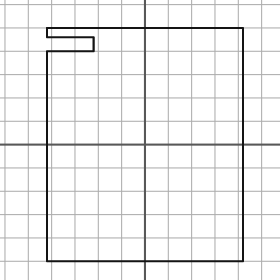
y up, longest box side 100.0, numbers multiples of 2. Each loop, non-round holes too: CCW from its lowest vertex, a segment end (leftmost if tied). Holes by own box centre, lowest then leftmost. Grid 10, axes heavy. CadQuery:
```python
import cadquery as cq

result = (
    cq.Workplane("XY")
    .moveTo(-42.0, -50.0)
    .lineTo(42.0, -50.0)
    .lineTo(42.0, 50.0)
    .lineTo(-42.0, 50.0)
    .lineTo(-42.0, 46.0)
    .lineTo(-22.0, 46.0)
    .lineTo(-22.0, 40.0)
    .lineTo(-42.0, 40.0)
    .close()
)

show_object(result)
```